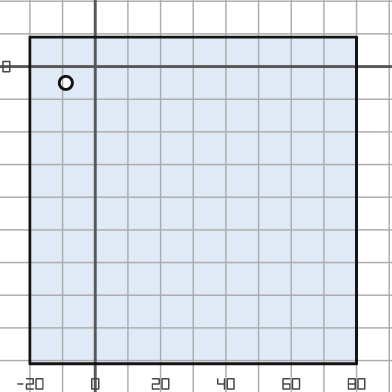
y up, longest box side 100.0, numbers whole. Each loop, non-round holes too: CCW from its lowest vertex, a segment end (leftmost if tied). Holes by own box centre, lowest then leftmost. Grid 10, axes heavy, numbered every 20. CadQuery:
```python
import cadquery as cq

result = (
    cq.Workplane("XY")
    .moveTo(-20.0, -91.0)
    .lineTo(80.0, -91.0)
    .lineTo(80.0, 9.0)
    .lineTo(-20.0, 9.0)
    .close()
    .moveTo(-9.0, -5.0)
    .circle(2.0)
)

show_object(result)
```